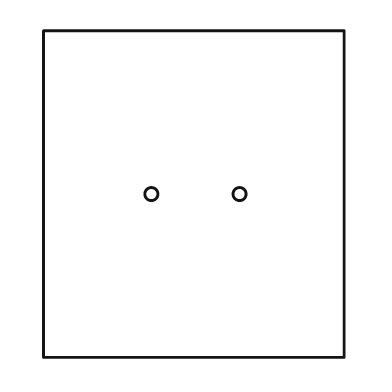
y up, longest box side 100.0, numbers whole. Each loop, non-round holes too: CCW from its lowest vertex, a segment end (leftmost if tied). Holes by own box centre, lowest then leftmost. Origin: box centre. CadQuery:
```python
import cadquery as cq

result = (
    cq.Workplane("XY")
    .moveTo(-46.0, -50.0)
    .lineTo(46.0, -50.0)
    .lineTo(46.0, 50.0)
    .lineTo(-46.0, 50.0)
    .close()
    .moveTo(-13.0, 0.0)
    .circle(2.0)
    .moveTo(14.0, 0.0)
    .circle(2.0)
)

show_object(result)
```